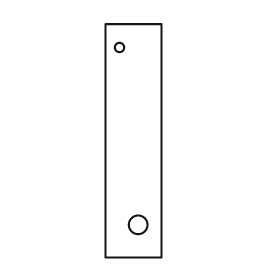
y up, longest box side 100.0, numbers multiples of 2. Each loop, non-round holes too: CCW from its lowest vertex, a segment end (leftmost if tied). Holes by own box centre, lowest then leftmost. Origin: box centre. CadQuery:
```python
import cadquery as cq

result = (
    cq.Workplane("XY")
    .moveTo(-12.0, -50.0)
    .lineTo(12.0, -50.0)
    .lineTo(12.0, 50.0)
    .lineTo(-12.0, 50.0)
    .close()
    .moveTo(2.0, -36.0)
    .circle(4.0)
    .moveTo(-6.0, 40.0)
    .circle(2.0)
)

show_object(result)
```